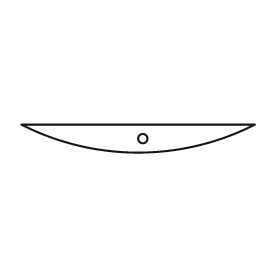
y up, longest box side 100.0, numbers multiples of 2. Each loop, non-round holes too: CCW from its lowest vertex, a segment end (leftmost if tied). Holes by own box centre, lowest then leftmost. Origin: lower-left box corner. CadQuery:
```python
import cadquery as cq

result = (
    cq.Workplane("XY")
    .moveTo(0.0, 12.0)
    .threePointArc((50.0, 0.0), (100.0, 12.0))
    .close()
    .moveTo(52.0, 6.0)
    .circle(2.0)
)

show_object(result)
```